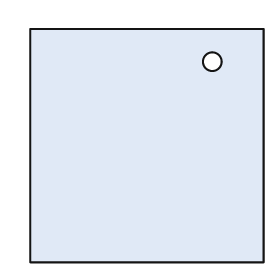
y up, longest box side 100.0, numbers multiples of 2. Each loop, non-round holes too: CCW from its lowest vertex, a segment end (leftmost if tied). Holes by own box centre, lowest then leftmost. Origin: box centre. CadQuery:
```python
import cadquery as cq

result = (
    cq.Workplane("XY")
    .moveTo(-50.0, -50.0)
    .lineTo(50.0, -50.0)
    .lineTo(50.0, 50.0)
    .lineTo(-50.0, 50.0)
    .close()
    .moveTo(28.0, 36.0)
    .circle(4.0)
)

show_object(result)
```